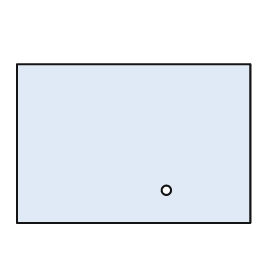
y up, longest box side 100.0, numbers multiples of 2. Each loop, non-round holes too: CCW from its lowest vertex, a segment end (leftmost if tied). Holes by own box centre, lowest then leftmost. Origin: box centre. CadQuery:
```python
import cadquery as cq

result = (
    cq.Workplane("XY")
    .moveTo(-50.0, -34.0)
    .lineTo(50.0, -34.0)
    .lineTo(50.0, 34.0)
    .lineTo(-50.0, 34.0)
    .close()
    .moveTo(14.0, -20.0)
    .circle(2.0)
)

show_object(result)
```